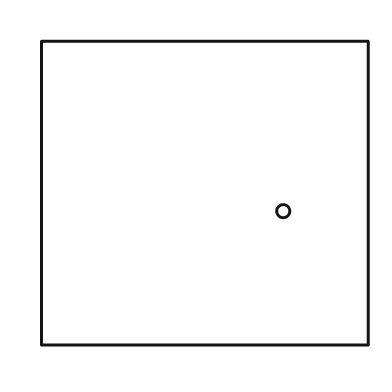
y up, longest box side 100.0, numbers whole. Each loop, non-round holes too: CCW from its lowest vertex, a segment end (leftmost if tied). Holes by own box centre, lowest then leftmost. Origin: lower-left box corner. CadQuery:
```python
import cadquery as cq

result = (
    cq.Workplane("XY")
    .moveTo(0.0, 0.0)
    .lineTo(100.0, 0.0)
    .lineTo(100.0, 93.0)
    .lineTo(0.0, 93.0)
    .close()
    .moveTo(74.0, 41.0)
    .circle(2.0)
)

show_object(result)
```